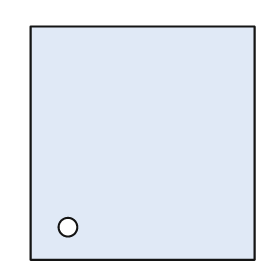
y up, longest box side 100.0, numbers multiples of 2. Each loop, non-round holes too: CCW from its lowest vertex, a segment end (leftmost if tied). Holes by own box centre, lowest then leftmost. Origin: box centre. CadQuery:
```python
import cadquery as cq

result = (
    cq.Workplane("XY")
    .moveTo(-48.0, -50.0)
    .lineTo(48.0, -50.0)
    .lineTo(48.0, 50.0)
    .lineTo(-48.0, 50.0)
    .close()
    .moveTo(-32.0, -36.0)
    .circle(4.0)
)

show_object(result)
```